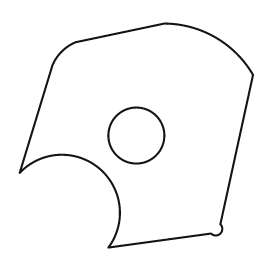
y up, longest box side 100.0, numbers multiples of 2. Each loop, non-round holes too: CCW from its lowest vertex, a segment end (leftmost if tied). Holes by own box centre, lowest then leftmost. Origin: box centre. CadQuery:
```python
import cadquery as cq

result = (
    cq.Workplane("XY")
    .moveTo(-12.0, -48.0)
    .lineTo(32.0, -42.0)
    .threePointArc((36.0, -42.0), (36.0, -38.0))
    .lineTo(50.0, 26.0)
    .threePointArc((34.0, 42.0), (12.0, 48.0))
    .lineTo(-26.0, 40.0)
    .threePointArc((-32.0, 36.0), (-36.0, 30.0))
    .lineTo(-50.0, -16.0)
    .threePointArc((-16.0, -14.0), (-12.0, -48.0))
    .close()
    .moveTo(0.0, 0.0)
    .circle(12.0)
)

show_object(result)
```